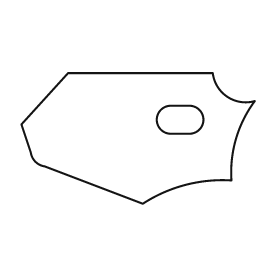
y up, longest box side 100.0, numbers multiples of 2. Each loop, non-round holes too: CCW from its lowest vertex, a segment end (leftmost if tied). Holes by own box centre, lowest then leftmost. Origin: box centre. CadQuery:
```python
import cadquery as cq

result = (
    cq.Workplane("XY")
    .moveTo(2.0, -28.0)
    .threePointArc((20.0, -20.0), (40.0, -18.0))
    .threePointArc((42.0, 0.0), (50.0, 16.0))
    .threePointArc((38.0, 18.0), (32.0, 28.0))
    .lineTo(-30.0, 28.0)
    .lineTo(-50.0, 6.0)
    .lineTo(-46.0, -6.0)
    .threePointArc((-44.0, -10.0), (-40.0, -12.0))
    .close()
    .moveTo(14.0, 2.0)
    .lineTo(22.0, 2.0)
    .threePointArc((28.0, 8.0), (22.0, 14.0))
    .lineTo(14.0, 14.0)
    .threePointArc((8.0, 8.0), (14.0, 2.0))
    .close()
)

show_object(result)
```